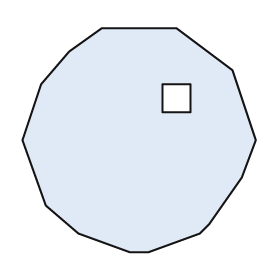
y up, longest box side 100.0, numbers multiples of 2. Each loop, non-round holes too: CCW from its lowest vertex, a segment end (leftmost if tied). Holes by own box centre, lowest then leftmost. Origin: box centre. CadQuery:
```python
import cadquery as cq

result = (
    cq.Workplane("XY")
    .moveTo(-4.0, -48.0)
    .lineTo(4.0, -48.0)
    .lineTo(26.0, -40.0)
    .lineTo(30.0, -36.0)
    .lineTo(44.0, -16.0)
    .lineTo(50.0, 0.0)
    .lineTo(40.0, 30.0)
    .lineTo(16.0, 48.0)
    .lineTo(-16.0, 48.0)
    .lineTo(-30.0, 38.0)
    .lineTo(-42.0, 24.0)
    .lineTo(-50.0, 0.0)
    .lineTo(-40.0, -28.0)
    .lineTo(-26.0, -40.0)
    .close()
    .moveTo(10.0, 12.0)
    .lineTo(22.0, 12.0)
    .lineTo(22.0, 24.0)
    .lineTo(10.0, 24.0)
    .close()
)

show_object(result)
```